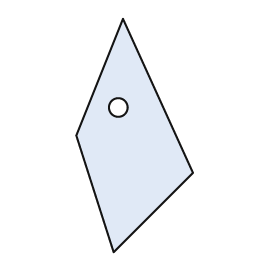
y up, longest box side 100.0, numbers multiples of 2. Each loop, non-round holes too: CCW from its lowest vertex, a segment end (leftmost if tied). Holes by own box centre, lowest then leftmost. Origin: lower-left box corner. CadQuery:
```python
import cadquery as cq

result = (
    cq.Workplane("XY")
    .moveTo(16.0, 0.0)
    .lineTo(50.0, 34.0)
    .lineTo(20.0, 100.0)
    .lineTo(0.0, 50.0)
    .close()
    .moveTo(18.0, 62.0)
    .circle(4.0)
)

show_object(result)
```